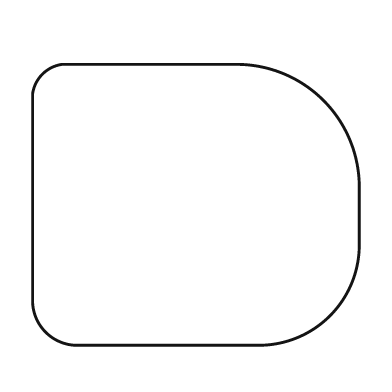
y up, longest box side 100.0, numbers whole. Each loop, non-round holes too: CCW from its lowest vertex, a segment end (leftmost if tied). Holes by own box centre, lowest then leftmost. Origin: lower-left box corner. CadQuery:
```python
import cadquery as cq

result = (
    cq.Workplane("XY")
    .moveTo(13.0, 0.0)
    .lineTo(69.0, 0.0)
    .threePointArc((91.0, 9.0), (100.0, 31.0))
    .lineTo(100.0, 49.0)
    .threePointArc((89.0, 75.0), (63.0, 86.0))
    .lineTo(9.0, 86.0)
    .threePointArc((3.0, 83.0), (0.0, 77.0))
    .lineTo(0.0, 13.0)
    .threePointArc((4.0, 4.0), (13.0, 0.0))
    .close()
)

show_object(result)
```